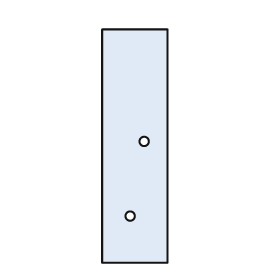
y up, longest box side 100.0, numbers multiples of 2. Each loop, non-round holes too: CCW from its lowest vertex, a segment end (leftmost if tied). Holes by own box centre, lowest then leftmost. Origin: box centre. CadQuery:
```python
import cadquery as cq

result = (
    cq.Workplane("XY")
    .moveTo(-14.0, -50.0)
    .lineTo(14.0, -50.0)
    .lineTo(14.0, 50.0)
    .lineTo(-14.0, 50.0)
    .close()
    .moveTo(-2.0, -30.0)
    .circle(2.0)
    .moveTo(4.0, 2.0)
    .circle(2.0)
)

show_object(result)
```